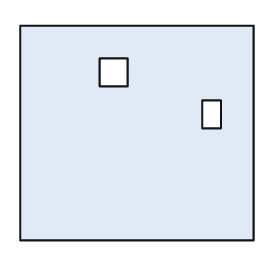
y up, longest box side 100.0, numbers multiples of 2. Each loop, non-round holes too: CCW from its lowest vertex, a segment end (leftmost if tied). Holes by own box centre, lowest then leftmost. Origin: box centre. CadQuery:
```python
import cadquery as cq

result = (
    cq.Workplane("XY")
    .moveTo(-50.0, -46.0)
    .lineTo(50.0, -46.0)
    .lineTo(50.0, 46.0)
    .lineTo(-50.0, 46.0)
    .close()
    .moveTo(28.0, 2.0)
    .lineTo(36.0, 2.0)
    .lineTo(36.0, 14.0)
    .lineTo(28.0, 14.0)
    .close()
    .moveTo(-16.0, 20.0)
    .lineTo(-4.0, 20.0)
    .lineTo(-4.0, 32.0)
    .lineTo(-16.0, 32.0)
    .close()
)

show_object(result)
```